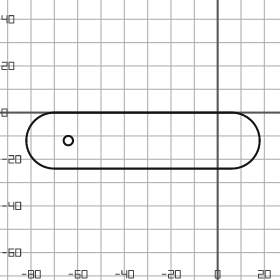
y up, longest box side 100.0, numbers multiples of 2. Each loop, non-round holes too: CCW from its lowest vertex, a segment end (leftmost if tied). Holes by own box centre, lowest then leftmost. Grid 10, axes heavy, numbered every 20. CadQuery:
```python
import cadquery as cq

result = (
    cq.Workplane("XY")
    .moveTo(-70.0, -24.0)
    .lineTo(6.0, -24.0)
    .threePointArc((18.0, -12.0), (6.0, 0.0))
    .lineTo(-70.0, 0.0)
    .threePointArc((-82.0, -12.0), (-70.0, -24.0))
    .close()
    .moveTo(-64.0, -12.0)
    .circle(2.0)
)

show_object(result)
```